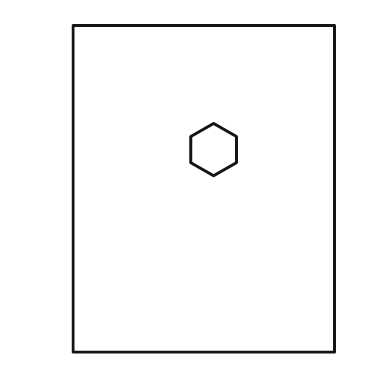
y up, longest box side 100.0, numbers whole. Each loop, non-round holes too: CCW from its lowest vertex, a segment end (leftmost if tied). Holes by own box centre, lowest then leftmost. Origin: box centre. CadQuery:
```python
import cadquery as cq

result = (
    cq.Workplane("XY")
    .moveTo(-40.0, -50.0)
    .lineTo(40.0, -50.0)
    .lineTo(40.0, 50.0)
    .lineTo(-40.0, 50.0)
    .close()
    .moveTo(3.0, 4.0)
    .lineTo(10.0, 8.0)
    .lineTo(10.0, 16.0)
    .lineTo(3.0, 20.0)
    .lineTo(-4.0, 16.0)
    .lineTo(-4.0, 8.0)
    .close()
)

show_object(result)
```